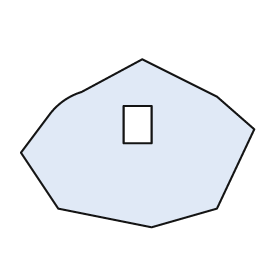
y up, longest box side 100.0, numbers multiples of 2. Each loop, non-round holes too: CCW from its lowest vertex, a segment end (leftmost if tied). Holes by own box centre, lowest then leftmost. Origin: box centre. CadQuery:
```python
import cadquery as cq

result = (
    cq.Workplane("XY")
    .moveTo(6.0, -36.0)
    .lineTo(34.0, -28.0)
    .lineTo(50.0, 6.0)
    .lineTo(34.0, 20.0)
    .lineTo(2.0, 36.0)
    .lineTo(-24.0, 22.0)
    .threePointArc((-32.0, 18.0), (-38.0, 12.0))
    .lineTo(-50.0, -4.0)
    .lineTo(-34.0, -28.0)
    .close()
    .moveTo(-6.0, 0.0)
    .lineTo(6.0, 0.0)
    .lineTo(6.0, 16.0)
    .lineTo(-6.0, 16.0)
    .close()
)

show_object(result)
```